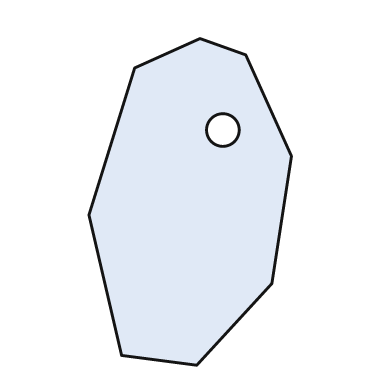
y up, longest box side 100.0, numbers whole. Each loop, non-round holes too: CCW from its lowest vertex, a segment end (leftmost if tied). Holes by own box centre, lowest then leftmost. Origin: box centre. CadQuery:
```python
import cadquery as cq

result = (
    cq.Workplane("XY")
    .moveTo(2.0, -50.0)
    .lineTo(25.0, -25.0)
    .lineTo(31.0, 14.0)
    .lineTo(17.0, 45.0)
    .lineTo(3.0, 50.0)
    .lineTo(-17.0, 41.0)
    .lineTo(-31.0, -4.0)
    .lineTo(-21.0, -47.0)
    .close()
    .moveTo(10.0, 22.0)
    .circle(5.0)
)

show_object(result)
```